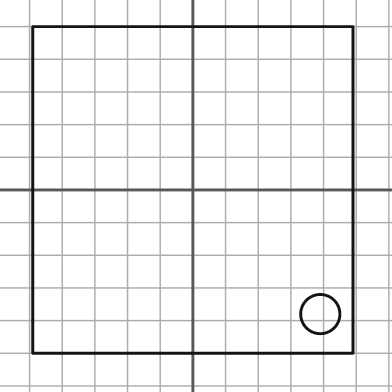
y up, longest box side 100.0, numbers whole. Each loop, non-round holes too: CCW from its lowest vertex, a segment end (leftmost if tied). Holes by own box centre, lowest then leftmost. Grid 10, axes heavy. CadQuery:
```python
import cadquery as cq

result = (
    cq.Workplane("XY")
    .moveTo(-49.0, -50.0)
    .lineTo(49.0, -50.0)
    .lineTo(49.0, 50.0)
    .lineTo(-49.0, 50.0)
    .close()
    .moveTo(39.0, -38.0)
    .circle(6.0)
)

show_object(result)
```